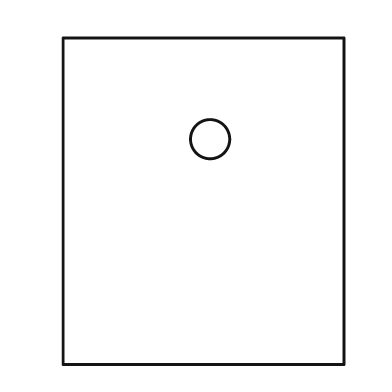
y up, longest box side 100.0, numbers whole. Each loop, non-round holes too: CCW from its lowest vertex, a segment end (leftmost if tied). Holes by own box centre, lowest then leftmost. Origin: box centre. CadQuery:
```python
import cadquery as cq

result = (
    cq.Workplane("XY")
    .moveTo(-43.0, -50.0)
    .lineTo(43.0, -50.0)
    .lineTo(43.0, 50.0)
    .lineTo(-43.0, 50.0)
    .close()
    .moveTo(2.0, 19.0)
    .circle(6.0)
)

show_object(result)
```